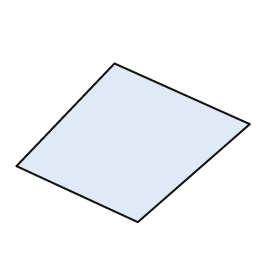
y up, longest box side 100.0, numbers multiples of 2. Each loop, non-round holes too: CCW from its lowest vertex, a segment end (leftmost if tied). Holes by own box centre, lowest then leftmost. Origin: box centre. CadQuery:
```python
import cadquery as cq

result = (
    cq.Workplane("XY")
    .moveTo(2.0, -34.0)
    .lineTo(50.0, 8.0)
    .lineTo(-8.0, 34.0)
    .lineTo(-50.0, -10.0)
    .close()
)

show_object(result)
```